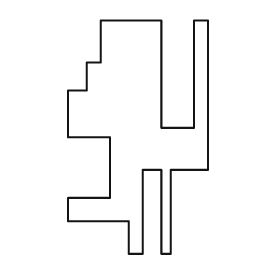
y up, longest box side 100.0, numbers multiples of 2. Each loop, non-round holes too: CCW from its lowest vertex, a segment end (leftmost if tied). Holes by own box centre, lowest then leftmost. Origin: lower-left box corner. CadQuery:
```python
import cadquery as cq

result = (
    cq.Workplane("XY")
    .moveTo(26.0, 0.0)
    .lineTo(32.0, 0.0)
    .lineTo(32.0, 36.0)
    .lineTo(40.0, 36.0)
    .lineTo(40.0, 0.0)
    .lineTo(44.0, 0.0)
    .lineTo(44.0, 36.0)
    .lineTo(60.0, 36.0)
    .lineTo(60.0, 100.0)
    .lineTo(54.0, 100.0)
    .lineTo(54.0, 54.0)
    .lineTo(40.0, 54.0)
    .lineTo(40.0, 100.0)
    .lineTo(14.0, 100.0)
    .lineTo(14.0, 82.0)
    .lineTo(8.0, 82.0)
    .lineTo(8.0, 70.0)
    .lineTo(0.0, 70.0)
    .lineTo(0.0, 50.0)
    .lineTo(18.0, 50.0)
    .lineTo(18.0, 24.0)
    .lineTo(0.0, 24.0)
    .lineTo(0.0, 14.0)
    .lineTo(26.0, 14.0)
    .close()
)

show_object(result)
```